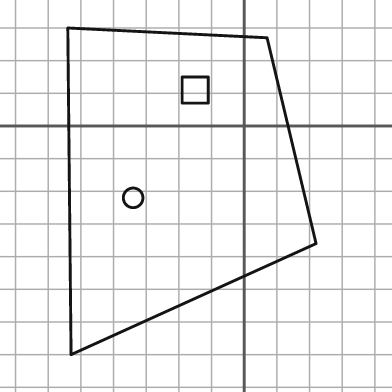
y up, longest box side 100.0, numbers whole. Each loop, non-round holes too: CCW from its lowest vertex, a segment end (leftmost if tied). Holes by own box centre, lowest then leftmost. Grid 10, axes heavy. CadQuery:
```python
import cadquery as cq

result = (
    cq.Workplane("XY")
    .moveTo(-53.0, -70.0)
    .lineTo(22.0, -36.0)
    .lineTo(7.0, 27.0)
    .lineTo(-54.0, 30.0)
    .close()
    .moveTo(-34.0, -22.0)
    .circle(3.0)
    .moveTo(-19.0, 7.0)
    .lineTo(-11.0, 7.0)
    .lineTo(-11.0, 15.0)
    .lineTo(-19.0, 15.0)
    .close()
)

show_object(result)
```